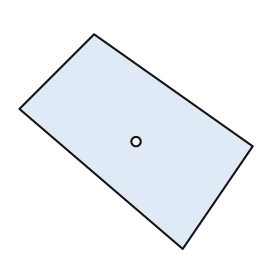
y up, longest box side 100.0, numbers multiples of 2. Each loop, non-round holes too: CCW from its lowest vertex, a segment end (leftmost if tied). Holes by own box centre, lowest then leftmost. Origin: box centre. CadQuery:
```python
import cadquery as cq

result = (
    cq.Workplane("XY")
    .moveTo(20.0, -46.0)
    .lineTo(50.0, -2.0)
    .lineTo(-18.0, 46.0)
    .lineTo(-50.0, 14.0)
    .close()
    .moveTo(0.0, 0.0)
    .circle(2.0)
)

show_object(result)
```